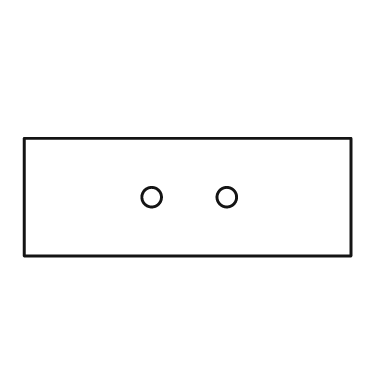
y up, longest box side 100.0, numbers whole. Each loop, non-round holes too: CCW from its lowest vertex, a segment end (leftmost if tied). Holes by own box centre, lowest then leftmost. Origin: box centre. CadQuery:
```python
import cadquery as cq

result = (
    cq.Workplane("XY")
    .moveTo(-50.0, -18.0)
    .lineTo(50.0, -18.0)
    .lineTo(50.0, 18.0)
    .lineTo(-50.0, 18.0)
    .close()
    .moveTo(-11.0, 0.0)
    .circle(3.0)
    .moveTo(12.0, 0.0)
    .circle(3.0)
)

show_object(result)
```